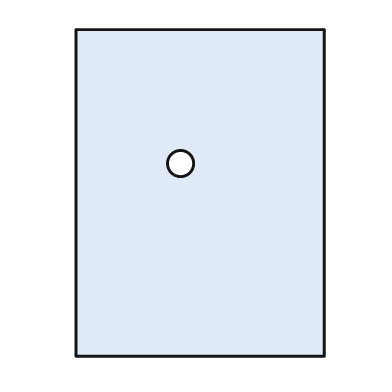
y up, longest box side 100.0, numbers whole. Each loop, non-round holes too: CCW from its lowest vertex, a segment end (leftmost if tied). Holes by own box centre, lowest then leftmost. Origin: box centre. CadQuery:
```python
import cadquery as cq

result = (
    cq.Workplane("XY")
    .moveTo(-38.0, -50.0)
    .lineTo(38.0, -50.0)
    .lineTo(38.0, 50.0)
    .lineTo(-38.0, 50.0)
    .close()
    .moveTo(-6.0, 9.0)
    .circle(4.0)
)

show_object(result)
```